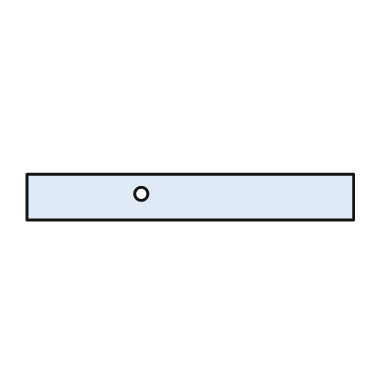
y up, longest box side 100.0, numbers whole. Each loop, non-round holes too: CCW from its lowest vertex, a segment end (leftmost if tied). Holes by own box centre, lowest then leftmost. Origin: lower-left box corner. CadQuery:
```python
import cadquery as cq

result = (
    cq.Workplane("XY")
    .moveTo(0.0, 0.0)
    .lineTo(100.0, 0.0)
    .lineTo(100.0, 14.0)
    .lineTo(0.0, 14.0)
    .close()
    .moveTo(35.0, 8.0)
    .circle(2.0)
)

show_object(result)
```